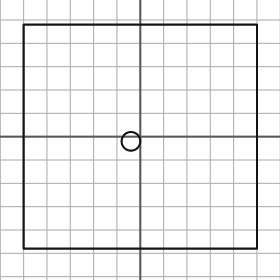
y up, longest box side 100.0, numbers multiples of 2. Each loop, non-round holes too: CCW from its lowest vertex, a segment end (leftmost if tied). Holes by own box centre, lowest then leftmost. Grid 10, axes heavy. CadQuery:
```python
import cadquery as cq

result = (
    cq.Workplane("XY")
    .moveTo(-50.0, -48.0)
    .lineTo(50.0, -48.0)
    .lineTo(50.0, 48.0)
    .lineTo(-50.0, 48.0)
    .close()
    .moveTo(-4.0, -2.0)
    .circle(4.0)
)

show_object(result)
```